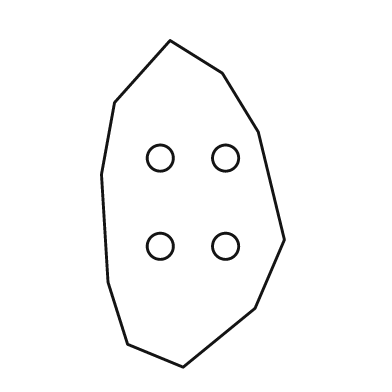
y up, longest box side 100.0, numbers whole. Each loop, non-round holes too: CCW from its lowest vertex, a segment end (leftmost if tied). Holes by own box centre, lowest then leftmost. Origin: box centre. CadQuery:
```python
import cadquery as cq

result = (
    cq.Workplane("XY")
    .moveTo(-3.0, -50.0)
    .lineTo(19.0, -32.0)
    .lineTo(28.0, -11.0)
    .lineTo(20.0, 22.0)
    .lineTo(9.0, 40.0)
    .lineTo(-7.0, 50.0)
    .lineTo(-24.0, 31.0)
    .lineTo(-28.0, 9.0)
    .lineTo(-26.0, -24.0)
    .lineTo(-20.0, -43.0)
    .close()
    .moveTo(-10.0, -13.0)
    .circle(4.0)
    .moveTo(10.0, -13.0)
    .circle(4.0)
    .moveTo(-10.0, 14.0)
    .circle(4.0)
    .moveTo(10.0, 14.0)
    .circle(4.0)
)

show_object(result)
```